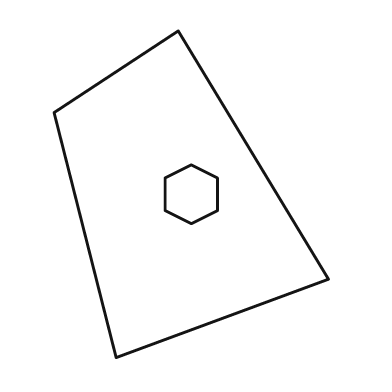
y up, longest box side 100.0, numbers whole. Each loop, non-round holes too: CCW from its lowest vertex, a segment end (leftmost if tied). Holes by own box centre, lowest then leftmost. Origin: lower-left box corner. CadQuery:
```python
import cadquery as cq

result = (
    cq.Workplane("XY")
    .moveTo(19.0, 0.0)
    .lineTo(84.0, 24.0)
    .lineTo(38.0, 100.0)
    .lineTo(0.0, 75.0)
    .close()
    .moveTo(42.0, 41.0)
    .lineTo(50.0, 45.0)
    .lineTo(50.0, 55.0)
    .lineTo(42.0, 59.0)
    .lineTo(34.0, 55.0)
    .lineTo(34.0, 45.0)
    .close()
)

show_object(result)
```